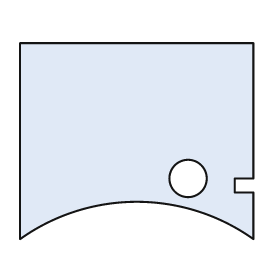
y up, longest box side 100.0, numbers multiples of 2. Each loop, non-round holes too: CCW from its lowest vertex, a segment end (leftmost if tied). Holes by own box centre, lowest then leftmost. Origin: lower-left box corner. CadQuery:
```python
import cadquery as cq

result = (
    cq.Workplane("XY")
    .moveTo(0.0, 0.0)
    .threePointArc((50.0, 16.0), (100.0, 0.0))
    .lineTo(100.0, 20.0)
    .lineTo(92.0, 20.0)
    .lineTo(92.0, 26.0)
    .lineTo(100.0, 26.0)
    .lineTo(100.0, 84.0)
    .lineTo(0.0, 84.0)
    .close()
    .moveTo(72.0, 26.0)
    .circle(8.0)
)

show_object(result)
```